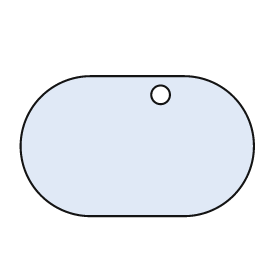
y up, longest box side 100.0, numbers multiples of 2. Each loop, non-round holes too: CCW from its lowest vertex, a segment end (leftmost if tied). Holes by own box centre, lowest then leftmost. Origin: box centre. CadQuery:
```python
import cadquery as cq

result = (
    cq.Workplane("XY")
    .moveTo(-20.0, -30.0)
    .lineTo(20.0, -30.0)
    .threePointArc((50.0, 0.0), (20.0, 30.0))
    .lineTo(-20.0, 30.0)
    .threePointArc((-50.0, 0.0), (-20.0, -30.0))
    .close()
    .moveTo(10.0, 22.0)
    .circle(4.0)
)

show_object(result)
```